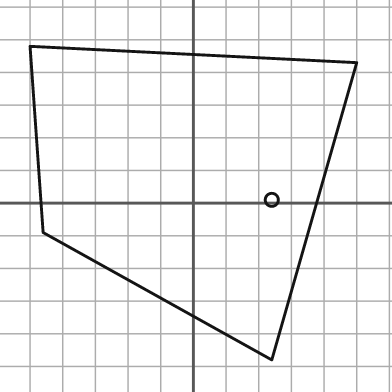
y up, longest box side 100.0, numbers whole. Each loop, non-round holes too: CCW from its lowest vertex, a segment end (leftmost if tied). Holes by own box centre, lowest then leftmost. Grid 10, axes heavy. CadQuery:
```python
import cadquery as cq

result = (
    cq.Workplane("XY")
    .moveTo(24.0, -48.0)
    .lineTo(50.0, 43.0)
    .lineTo(-50.0, 48.0)
    .lineTo(-46.0, -9.0)
    .close()
    .moveTo(24.0, 1.0)
    .circle(2.0)
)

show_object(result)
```